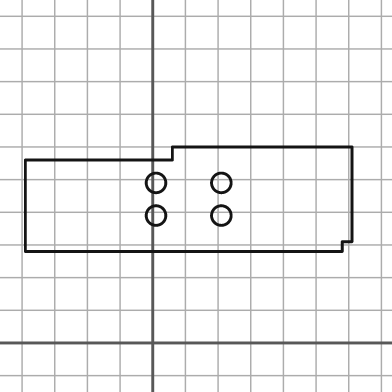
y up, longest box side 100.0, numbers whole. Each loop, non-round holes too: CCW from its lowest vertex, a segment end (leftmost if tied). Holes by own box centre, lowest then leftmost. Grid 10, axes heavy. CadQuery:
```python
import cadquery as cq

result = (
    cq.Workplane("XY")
    .moveTo(-39.0, 28.0)
    .lineTo(58.0, 28.0)
    .lineTo(58.0, 31.0)
    .lineTo(61.0, 31.0)
    .lineTo(61.0, 60.0)
    .lineTo(6.0, 60.0)
    .lineTo(6.0, 56.0)
    .lineTo(-39.0, 56.0)
    .close()
    .moveTo(1.0, 39.0)
    .circle(3.0)
    .moveTo(21.0, 39.0)
    .circle(3.0)
    .moveTo(1.0, 49.0)
    .circle(3.0)
    .moveTo(21.0, 49.0)
    .circle(3.0)
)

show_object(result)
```